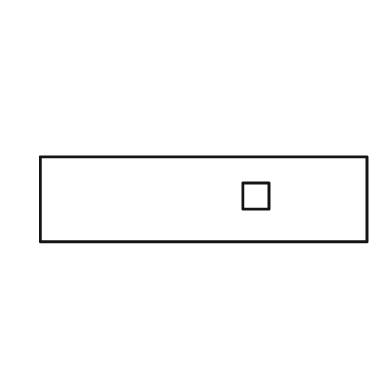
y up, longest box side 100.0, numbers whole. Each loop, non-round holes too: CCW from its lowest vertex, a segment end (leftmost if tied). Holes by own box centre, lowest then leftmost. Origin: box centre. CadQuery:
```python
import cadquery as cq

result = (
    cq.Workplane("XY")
    .moveTo(-50.0, -13.0)
    .lineTo(50.0, -13.0)
    .lineTo(50.0, 13.0)
    .lineTo(-50.0, 13.0)
    .close()
    .moveTo(12.0, -3.0)
    .lineTo(20.0, -3.0)
    .lineTo(20.0, 5.0)
    .lineTo(12.0, 5.0)
    .close()
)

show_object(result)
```